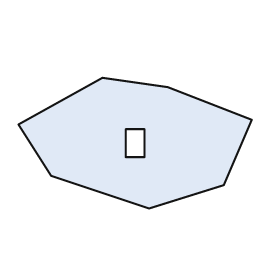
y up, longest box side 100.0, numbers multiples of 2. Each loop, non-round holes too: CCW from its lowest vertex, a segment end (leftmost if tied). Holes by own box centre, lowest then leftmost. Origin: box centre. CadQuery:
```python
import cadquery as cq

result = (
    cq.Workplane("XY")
    .moveTo(6.0, -28.0)
    .lineTo(38.0, -18.0)
    .lineTo(50.0, 10.0)
    .lineTo(14.0, 24.0)
    .lineTo(-14.0, 28.0)
    .lineTo(-50.0, 8.0)
    .lineTo(-36.0, -14.0)
    .close()
    .moveTo(-4.0, -6.0)
    .lineTo(4.0, -6.0)
    .lineTo(4.0, 6.0)
    .lineTo(-4.0, 6.0)
    .close()
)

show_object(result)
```